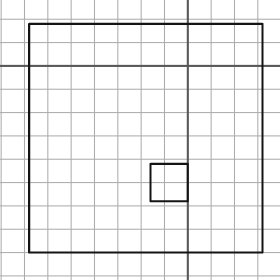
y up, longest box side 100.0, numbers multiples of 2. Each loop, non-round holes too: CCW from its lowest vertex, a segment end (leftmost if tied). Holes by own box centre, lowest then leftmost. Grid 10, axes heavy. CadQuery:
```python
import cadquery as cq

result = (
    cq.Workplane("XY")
    .moveTo(-68.0, -80.0)
    .lineTo(32.0, -80.0)
    .lineTo(32.0, 18.0)
    .lineTo(-68.0, 18.0)
    .close()
    .moveTo(-16.0, -58.0)
    .lineTo(0.0, -58.0)
    .lineTo(0.0, -42.0)
    .lineTo(-16.0, -42.0)
    .close()
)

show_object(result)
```